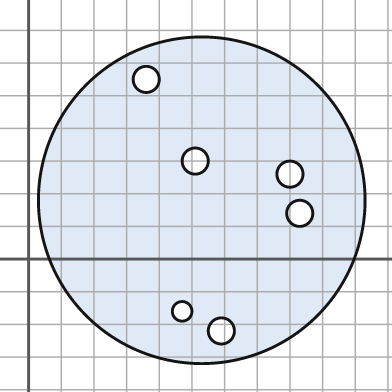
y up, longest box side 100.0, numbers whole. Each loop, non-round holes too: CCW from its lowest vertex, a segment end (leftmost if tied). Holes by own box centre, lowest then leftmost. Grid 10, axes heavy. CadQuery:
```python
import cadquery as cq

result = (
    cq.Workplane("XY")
    .moveTo(53.0, 18.0)
    .circle(50.0)
    .moveTo(59.0, -22.0)
    .circle(4.0)
    .moveTo(47.0, -16.0)
    .circle(3.0)
    .moveTo(83.0, 14.0)
    .circle(4.0)
    .moveTo(80.0, 26.0)
    .circle(4.0)
    .moveTo(51.0, 30.0)
    .circle(4.0)
    .moveTo(36.0, 55.0)
    .circle(4.0)
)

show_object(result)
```